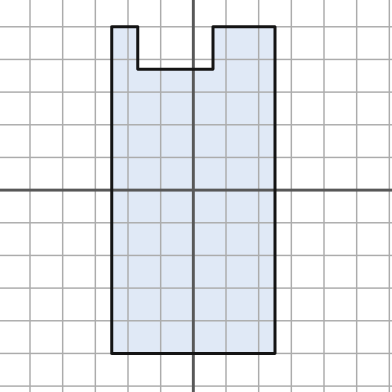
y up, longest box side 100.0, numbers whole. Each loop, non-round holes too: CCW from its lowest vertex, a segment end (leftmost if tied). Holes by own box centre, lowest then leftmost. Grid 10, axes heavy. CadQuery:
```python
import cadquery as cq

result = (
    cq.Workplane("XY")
    .moveTo(-25.0, -50.0)
    .lineTo(25.0, -50.0)
    .lineTo(25.0, 50.0)
    .lineTo(6.0, 50.0)
    .lineTo(6.0, 37.0)
    .lineTo(-17.0, 37.0)
    .lineTo(-17.0, 50.0)
    .lineTo(-25.0, 50.0)
    .close()
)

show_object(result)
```